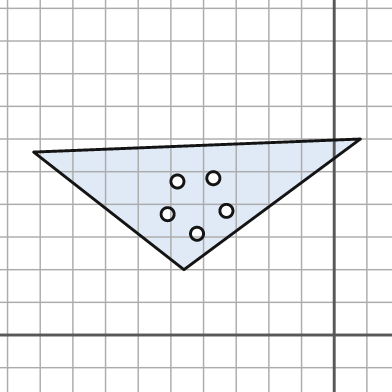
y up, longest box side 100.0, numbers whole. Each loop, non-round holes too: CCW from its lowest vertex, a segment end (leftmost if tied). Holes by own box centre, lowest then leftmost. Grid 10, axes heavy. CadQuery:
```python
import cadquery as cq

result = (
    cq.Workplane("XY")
    .moveTo(-46.0, 20.0)
    .lineTo(8.0, 60.0)
    .lineTo(-92.0, 56.0)
    .close()
    .moveTo(-42.0, 31.0)
    .circle(2.0)
    .moveTo(-51.0, 37.0)
    .circle(2.0)
    .moveTo(-33.0, 38.0)
    .circle(2.0)
    .moveTo(-48.0, 47.0)
    .circle(2.0)
    .moveTo(-37.0, 48.0)
    .circle(2.0)
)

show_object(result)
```